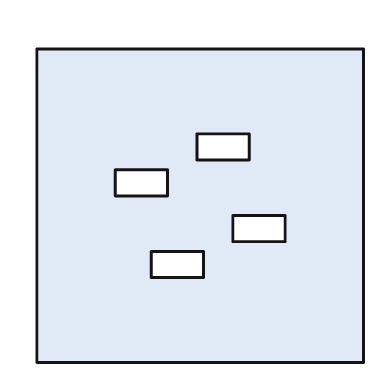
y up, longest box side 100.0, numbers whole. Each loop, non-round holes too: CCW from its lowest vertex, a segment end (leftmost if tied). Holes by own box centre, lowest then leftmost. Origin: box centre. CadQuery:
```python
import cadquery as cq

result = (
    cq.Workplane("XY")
    .moveTo(-50.0, -48.0)
    .lineTo(50.0, -48.0)
    .lineTo(50.0, 48.0)
    .lineTo(-50.0, 48.0)
    .close()
    .moveTo(-15.0, -22.0)
    .lineTo(1.0, -22.0)
    .lineTo(1.0, -14.0)
    .lineTo(-15.0, -14.0)
    .close()
    .moveTo(10.0, -11.0)
    .lineTo(26.0, -11.0)
    .lineTo(26.0, -3.0)
    .lineTo(10.0, -3.0)
    .close()
    .moveTo(-26.0, 3.0)
    .lineTo(-10.0, 3.0)
    .lineTo(-10.0, 11.0)
    .lineTo(-26.0, 11.0)
    .close()
    .moveTo(-1.0, 14.0)
    .lineTo(15.0, 14.0)
    .lineTo(15.0, 22.0)
    .lineTo(-1.0, 22.0)
    .close()
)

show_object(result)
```